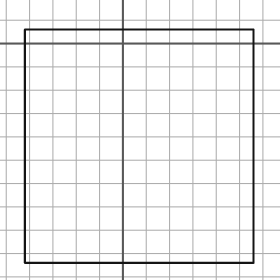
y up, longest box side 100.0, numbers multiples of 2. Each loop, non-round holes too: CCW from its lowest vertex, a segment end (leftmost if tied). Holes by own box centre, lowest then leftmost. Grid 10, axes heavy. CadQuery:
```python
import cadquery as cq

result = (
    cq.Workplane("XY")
    .moveTo(-42.0, -94.0)
    .lineTo(56.0, -94.0)
    .lineTo(56.0, 6.0)
    .lineTo(-42.0, 6.0)
    .close()
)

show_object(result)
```